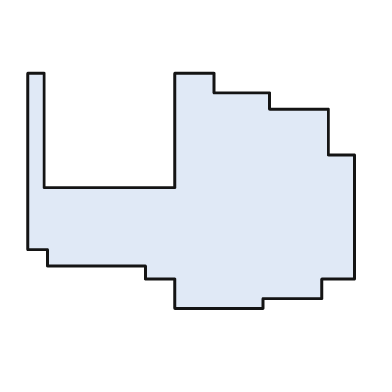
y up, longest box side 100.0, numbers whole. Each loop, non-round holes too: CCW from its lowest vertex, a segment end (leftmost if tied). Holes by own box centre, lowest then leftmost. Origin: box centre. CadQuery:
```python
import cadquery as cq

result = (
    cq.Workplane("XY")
    .moveTo(-5.0, -36.0)
    .lineTo(22.0, -36.0)
    .lineTo(22.0, -33.0)
    .lineTo(40.0, -33.0)
    .lineTo(40.0, -27.0)
    .lineTo(50.0, -27.0)
    .lineTo(50.0, 11.0)
    .lineTo(42.0, 11.0)
    .lineTo(42.0, 25.0)
    .lineTo(24.0, 25.0)
    .lineTo(24.0, 30.0)
    .lineTo(7.0, 30.0)
    .lineTo(7.0, 36.0)
    .lineTo(-5.0, 36.0)
    .lineTo(-5.0, 1.0)
    .lineTo(-45.0, 1.0)
    .lineTo(-45.0, 36.0)
    .lineTo(-50.0, 36.0)
    .lineTo(-50.0, -18.0)
    .lineTo(-44.0, -18.0)
    .lineTo(-44.0, -23.0)
    .lineTo(-14.0, -23.0)
    .lineTo(-14.0, -27.0)
    .lineTo(-5.0, -27.0)
    .close()
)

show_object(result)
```